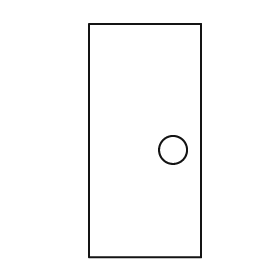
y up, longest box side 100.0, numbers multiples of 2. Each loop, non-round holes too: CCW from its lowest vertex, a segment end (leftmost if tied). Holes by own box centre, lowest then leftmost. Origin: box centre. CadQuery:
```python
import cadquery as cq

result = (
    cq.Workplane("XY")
    .moveTo(-24.0, -50.0)
    .lineTo(24.0, -50.0)
    .lineTo(24.0, 50.0)
    .lineTo(-24.0, 50.0)
    .close()
    .moveTo(12.0, -4.0)
    .circle(6.0)
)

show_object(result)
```